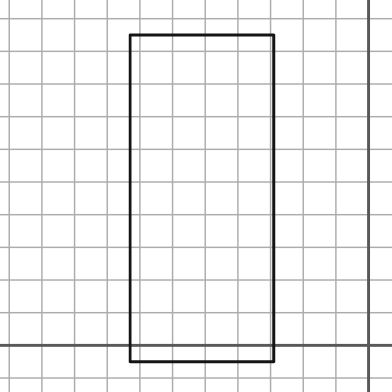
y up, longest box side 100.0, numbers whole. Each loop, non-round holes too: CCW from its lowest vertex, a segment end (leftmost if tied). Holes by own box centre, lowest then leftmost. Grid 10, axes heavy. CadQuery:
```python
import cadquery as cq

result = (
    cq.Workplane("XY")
    .moveTo(-73.0, -5.0)
    .lineTo(-29.0, -5.0)
    .lineTo(-29.0, 95.0)
    .lineTo(-73.0, 95.0)
    .close()
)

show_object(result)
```